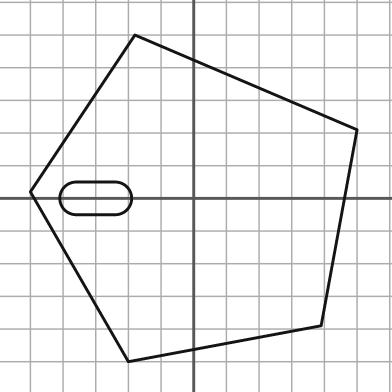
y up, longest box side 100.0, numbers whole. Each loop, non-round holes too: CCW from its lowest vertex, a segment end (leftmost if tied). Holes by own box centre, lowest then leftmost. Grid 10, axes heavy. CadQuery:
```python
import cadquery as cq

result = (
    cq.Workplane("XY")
    .moveTo(-20.0, -50.0)
    .lineTo(39.0, -39.0)
    .lineTo(50.0, 21.0)
    .lineTo(-18.0, 50.0)
    .lineTo(-50.0, 2.0)
    .close()
    .moveTo(-36.0, -5.0)
    .lineTo(-24.0, -5.0)
    .threePointArc((-19.0, 0.0), (-24.0, 5.0))
    .lineTo(-36.0, 5.0)
    .threePointArc((-41.0, 0.0), (-36.0, -5.0))
    .close()
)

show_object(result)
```